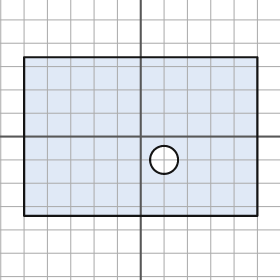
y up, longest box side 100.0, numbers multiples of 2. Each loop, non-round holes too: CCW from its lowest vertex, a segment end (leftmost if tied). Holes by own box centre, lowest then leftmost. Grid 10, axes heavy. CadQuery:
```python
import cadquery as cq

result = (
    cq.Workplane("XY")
    .moveTo(-50.0, -34.0)
    .lineTo(50.0, -34.0)
    .lineTo(50.0, 34.0)
    .lineTo(-50.0, 34.0)
    .close()
    .moveTo(10.0, -10.0)
    .circle(6.0)
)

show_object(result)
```